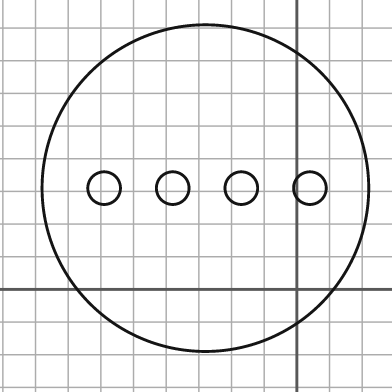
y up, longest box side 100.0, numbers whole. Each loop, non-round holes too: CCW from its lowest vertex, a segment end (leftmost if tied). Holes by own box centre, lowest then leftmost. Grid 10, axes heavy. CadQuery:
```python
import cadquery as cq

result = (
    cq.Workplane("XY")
    .moveTo(-28.0, 31.0)
    .circle(50.0)
    .moveTo(-59.0, 31.0)
    .circle(5.0)
    .moveTo(-38.0, 31.0)
    .circle(5.0)
    .moveTo(-17.0, 31.0)
    .circle(5.0)
    .moveTo(4.0, 31.0)
    .circle(5.0)
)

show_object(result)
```